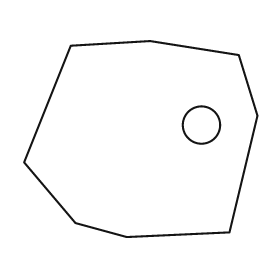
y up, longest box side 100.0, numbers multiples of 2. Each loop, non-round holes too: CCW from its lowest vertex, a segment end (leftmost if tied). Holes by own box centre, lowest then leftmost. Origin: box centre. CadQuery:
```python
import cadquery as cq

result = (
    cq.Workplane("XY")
    .moveTo(-6.0, -42.0)
    .lineTo(38.0, -40.0)
    .lineTo(50.0, 10.0)
    .lineTo(42.0, 36.0)
    .lineTo(4.0, 42.0)
    .lineTo(-30.0, 40.0)
    .lineTo(-50.0, -10.0)
    .lineTo(-28.0, -36.0)
    .close()
    .moveTo(26.0, 6.0)
    .circle(8.0)
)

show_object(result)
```